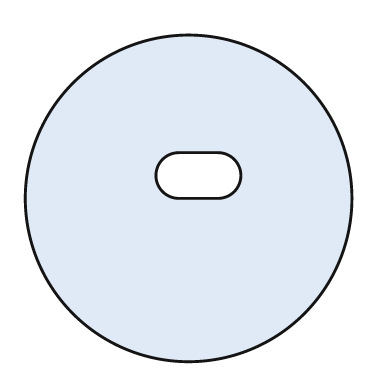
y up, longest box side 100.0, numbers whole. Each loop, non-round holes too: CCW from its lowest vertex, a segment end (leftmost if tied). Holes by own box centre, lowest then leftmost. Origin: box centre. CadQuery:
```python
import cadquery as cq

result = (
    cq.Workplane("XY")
    .moveTo(0.0, 0.0)
    .circle(50.0)
    .moveTo(-3.0, 0.0)
    .lineTo(9.0, 0.0)
    .threePointArc((16.0, 7.0), (9.0, 14.0))
    .lineTo(-3.0, 14.0)
    .threePointArc((-10.0, 7.0), (-3.0, 0.0))
    .close()
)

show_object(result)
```